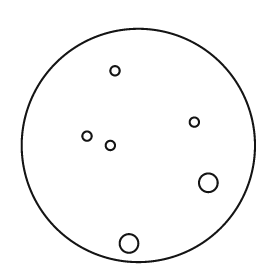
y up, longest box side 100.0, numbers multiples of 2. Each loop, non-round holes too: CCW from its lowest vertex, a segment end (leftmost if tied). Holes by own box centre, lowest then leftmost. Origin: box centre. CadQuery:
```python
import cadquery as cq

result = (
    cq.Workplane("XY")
    .moveTo(0.0, 0.0)
    .circle(50.0)
    .moveTo(-4.0, -42.0)
    .circle(4.0)
    .moveTo(30.0, -16.0)
    .circle(4.0)
    .moveTo(-12.0, 0.0)
    .circle(2.0)
    .moveTo(-22.0, 4.0)
    .circle(2.0)
    .moveTo(24.0, 10.0)
    .circle(2.0)
    .moveTo(-10.0, 32.0)
    .circle(2.0)
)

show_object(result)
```